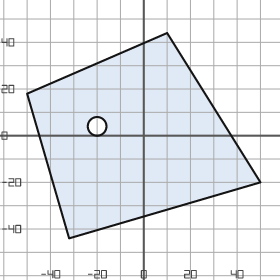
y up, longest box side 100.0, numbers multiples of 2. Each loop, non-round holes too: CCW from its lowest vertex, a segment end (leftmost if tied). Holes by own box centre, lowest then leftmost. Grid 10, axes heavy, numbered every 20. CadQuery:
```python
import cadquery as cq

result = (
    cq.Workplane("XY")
    .moveTo(-32.0, -44.0)
    .lineTo(50.0, -20.0)
    .lineTo(10.0, 44.0)
    .lineTo(-50.0, 18.0)
    .close()
    .moveTo(-20.0, 4.0)
    .circle(4.0)
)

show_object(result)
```